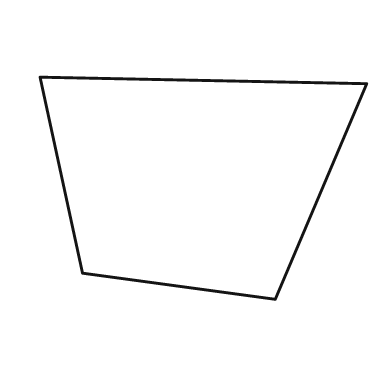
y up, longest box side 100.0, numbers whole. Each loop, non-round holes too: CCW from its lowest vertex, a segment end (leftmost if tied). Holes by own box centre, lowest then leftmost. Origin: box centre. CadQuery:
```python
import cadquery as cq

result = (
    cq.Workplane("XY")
    .moveTo(22.0, -34.0)
    .lineTo(50.0, 32.0)
    .lineTo(-50.0, 34.0)
    .lineTo(-37.0, -26.0)
    .close()
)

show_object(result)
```